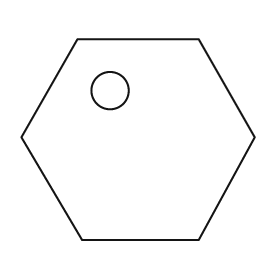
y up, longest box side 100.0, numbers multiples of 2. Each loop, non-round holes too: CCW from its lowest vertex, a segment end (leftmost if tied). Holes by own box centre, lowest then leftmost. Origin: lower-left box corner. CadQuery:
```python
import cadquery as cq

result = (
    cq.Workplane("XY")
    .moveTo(26.0, 0.0)
    .lineTo(76.0, 0.0)
    .lineTo(100.0, 44.0)
    .lineTo(76.0, 86.0)
    .lineTo(24.0, 86.0)
    .lineTo(0.0, 44.0)
    .close()
    .moveTo(38.0, 64.0)
    .circle(8.0)
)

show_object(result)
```